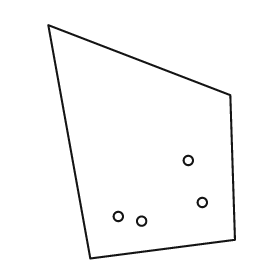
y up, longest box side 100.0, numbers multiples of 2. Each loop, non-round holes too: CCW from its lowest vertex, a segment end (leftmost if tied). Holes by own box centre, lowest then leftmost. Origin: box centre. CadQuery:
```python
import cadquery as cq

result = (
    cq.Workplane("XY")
    .moveTo(-22.0, -50.0)
    .lineTo(40.0, -42.0)
    .lineTo(38.0, 20.0)
    .lineTo(-40.0, 50.0)
    .close()
    .moveTo(0.0, -34.0)
    .circle(2.0)
    .moveTo(-10.0, -32.0)
    .circle(2.0)
    .moveTo(26.0, -26.0)
    .circle(2.0)
    .moveTo(20.0, -8.0)
    .circle(2.0)
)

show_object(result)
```